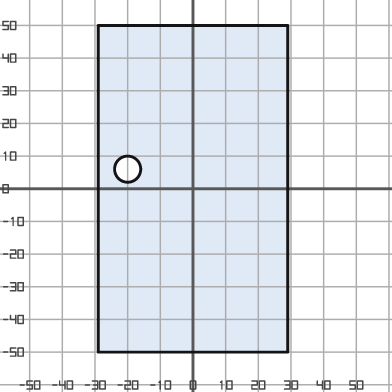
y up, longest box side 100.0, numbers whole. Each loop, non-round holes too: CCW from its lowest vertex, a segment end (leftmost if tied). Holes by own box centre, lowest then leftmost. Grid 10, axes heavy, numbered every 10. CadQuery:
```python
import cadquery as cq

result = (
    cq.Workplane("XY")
    .moveTo(-29.0, -50.0)
    .lineTo(29.0, -50.0)
    .lineTo(29.0, 50.0)
    .lineTo(-29.0, 50.0)
    .close()
    .moveTo(-20.0, 6.0)
    .circle(4.0)
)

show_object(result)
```